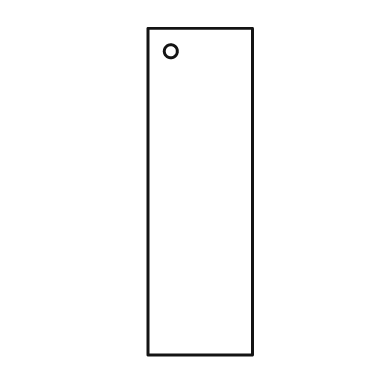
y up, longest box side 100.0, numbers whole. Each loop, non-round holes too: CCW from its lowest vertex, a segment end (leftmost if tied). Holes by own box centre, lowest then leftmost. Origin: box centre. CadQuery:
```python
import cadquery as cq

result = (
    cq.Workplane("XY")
    .moveTo(-16.0, -50.0)
    .lineTo(16.0, -50.0)
    .lineTo(16.0, 50.0)
    .lineTo(-16.0, 50.0)
    .close()
    .moveTo(-9.0, 43.0)
    .circle(2.0)
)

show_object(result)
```